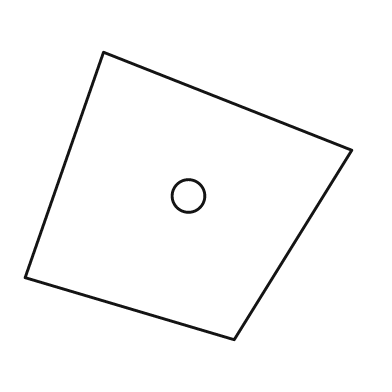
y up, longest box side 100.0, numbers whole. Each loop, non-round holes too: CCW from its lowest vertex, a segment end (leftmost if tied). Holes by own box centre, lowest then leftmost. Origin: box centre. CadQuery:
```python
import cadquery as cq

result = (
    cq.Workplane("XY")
    .moveTo(14.0, -44.0)
    .lineTo(50.0, 14.0)
    .lineTo(-26.0, 44.0)
    .lineTo(-50.0, -25.0)
    .close()
    .moveTo(0.0, 0.0)
    .circle(5.0)
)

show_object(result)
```